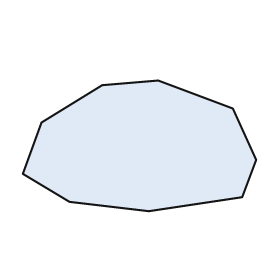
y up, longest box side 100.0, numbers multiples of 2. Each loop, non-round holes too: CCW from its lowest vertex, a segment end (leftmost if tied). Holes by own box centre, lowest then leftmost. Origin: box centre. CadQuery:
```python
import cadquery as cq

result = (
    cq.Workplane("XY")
    .moveTo(4.0, -28.0)
    .lineTo(44.0, -22.0)
    .lineTo(50.0, -6.0)
    .lineTo(40.0, 16.0)
    .lineTo(8.0, 28.0)
    .lineTo(-16.0, 26.0)
    .lineTo(-42.0, 10.0)
    .lineTo(-50.0, -12.0)
    .lineTo(-30.0, -24.0)
    .close()
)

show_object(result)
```